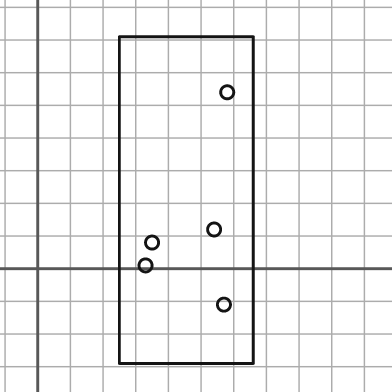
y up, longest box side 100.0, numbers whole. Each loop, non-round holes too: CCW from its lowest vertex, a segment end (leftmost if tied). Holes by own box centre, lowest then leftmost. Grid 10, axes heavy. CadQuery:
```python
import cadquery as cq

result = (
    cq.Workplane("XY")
    .moveTo(25.0, -29.0)
    .lineTo(66.0, -29.0)
    .lineTo(66.0, 71.0)
    .lineTo(25.0, 71.0)
    .close()
    .moveTo(57.0, -11.0)
    .circle(2.0)
    .moveTo(33.0, 1.0)
    .circle(2.0)
    .moveTo(35.0, 8.0)
    .circle(2.0)
    .moveTo(54.0, 12.0)
    .circle(2.0)
    .moveTo(58.0, 54.0)
    .circle(2.0)
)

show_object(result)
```